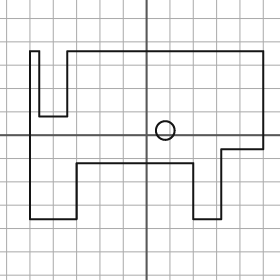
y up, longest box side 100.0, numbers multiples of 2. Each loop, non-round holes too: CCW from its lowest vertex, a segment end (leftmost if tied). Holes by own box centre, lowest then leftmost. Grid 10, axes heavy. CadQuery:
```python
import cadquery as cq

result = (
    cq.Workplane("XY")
    .moveTo(-50.0, -36.0)
    .lineTo(-30.0, -36.0)
    .lineTo(-30.0, -12.0)
    .lineTo(20.0, -12.0)
    .lineTo(20.0, -36.0)
    .lineTo(32.0, -36.0)
    .lineTo(32.0, -6.0)
    .lineTo(50.0, -6.0)
    .lineTo(50.0, 36.0)
    .lineTo(-34.0, 36.0)
    .lineTo(-34.0, 8.0)
    .lineTo(-46.0, 8.0)
    .lineTo(-46.0, 36.0)
    .lineTo(-50.0, 36.0)
    .close()
    .moveTo(8.0, 2.0)
    .circle(4.0)
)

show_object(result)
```